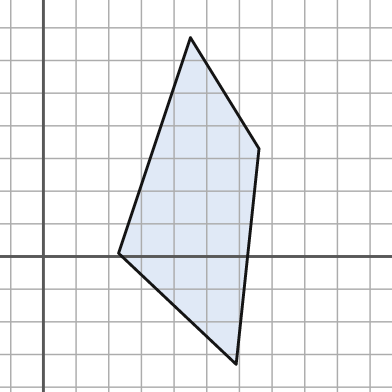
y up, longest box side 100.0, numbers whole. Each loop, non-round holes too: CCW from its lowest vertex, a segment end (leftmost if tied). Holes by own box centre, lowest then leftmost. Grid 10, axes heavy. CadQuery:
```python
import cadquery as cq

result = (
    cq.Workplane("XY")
    .moveTo(59.0, -33.0)
    .lineTo(66.0, 33.0)
    .lineTo(45.0, 67.0)
    .lineTo(23.0, 1.0)
    .close()
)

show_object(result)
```